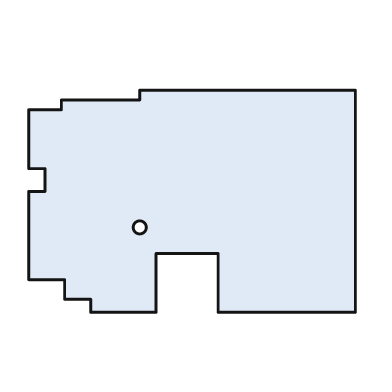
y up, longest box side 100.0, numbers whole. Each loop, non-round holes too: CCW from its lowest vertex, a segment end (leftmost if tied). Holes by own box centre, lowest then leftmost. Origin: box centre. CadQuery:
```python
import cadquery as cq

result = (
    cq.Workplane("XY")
    .moveTo(-31.0, -34.0)
    .lineTo(-11.0, -34.0)
    .lineTo(-11.0, -16.0)
    .lineTo(8.0, -16.0)
    .lineTo(8.0, -34.0)
    .lineTo(50.0, -34.0)
    .lineTo(50.0, 34.0)
    .lineTo(-16.0, 34.0)
    .lineTo(-16.0, 31.0)
    .lineTo(-40.0, 31.0)
    .lineTo(-40.0, 28.0)
    .lineTo(-50.0, 28.0)
    .lineTo(-50.0, 10.0)
    .lineTo(-45.0, 10.0)
    .lineTo(-45.0, 3.0)
    .lineTo(-50.0, 3.0)
    .lineTo(-50.0, -24.0)
    .lineTo(-39.0, -24.0)
    .lineTo(-39.0, -30.0)
    .lineTo(-31.0, -30.0)
    .close()
    .moveTo(-16.0, -8.0)
    .circle(2.0)
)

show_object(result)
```